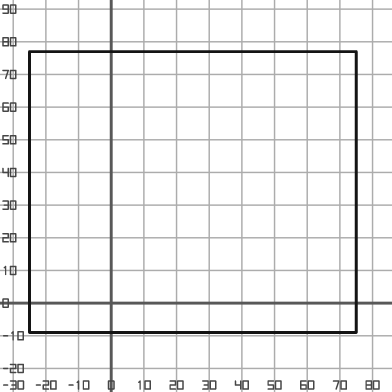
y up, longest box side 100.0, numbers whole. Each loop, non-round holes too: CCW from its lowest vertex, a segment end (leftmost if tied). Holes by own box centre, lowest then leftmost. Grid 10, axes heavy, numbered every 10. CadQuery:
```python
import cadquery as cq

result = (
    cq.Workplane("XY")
    .moveTo(-25.0, -9.0)
    .lineTo(75.0, -9.0)
    .lineTo(75.0, 77.0)
    .lineTo(-25.0, 77.0)
    .close()
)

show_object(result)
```